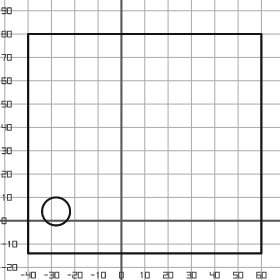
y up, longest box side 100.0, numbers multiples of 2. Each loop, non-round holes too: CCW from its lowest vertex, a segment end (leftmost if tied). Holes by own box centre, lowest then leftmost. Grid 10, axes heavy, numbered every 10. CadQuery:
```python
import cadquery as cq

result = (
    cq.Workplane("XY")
    .moveTo(-40.0, -14.0)
    .lineTo(60.0, -14.0)
    .lineTo(60.0, 80.0)
    .lineTo(-40.0, 80.0)
    .close()
    .moveTo(-28.0, 4.0)
    .circle(6.0)
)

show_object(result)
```